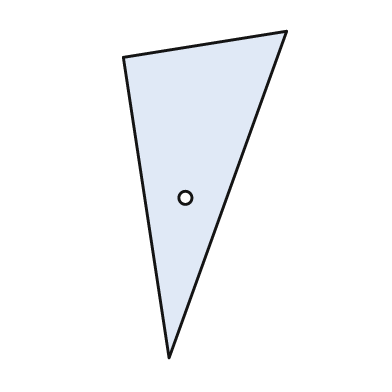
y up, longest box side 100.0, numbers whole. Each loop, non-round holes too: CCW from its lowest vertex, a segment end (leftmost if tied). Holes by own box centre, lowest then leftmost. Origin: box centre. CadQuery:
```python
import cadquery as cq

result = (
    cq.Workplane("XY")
    .moveTo(-11.0, -50.0)
    .lineTo(25.0, 50.0)
    .lineTo(-25.0, 42.0)
    .close()
    .moveTo(-6.0, -1.0)
    .circle(2.0)
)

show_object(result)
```